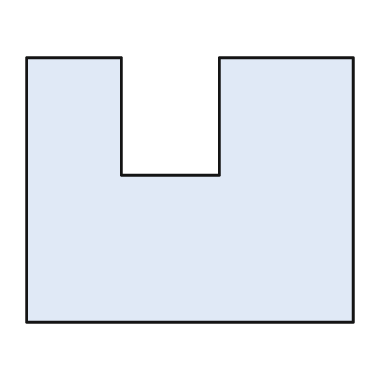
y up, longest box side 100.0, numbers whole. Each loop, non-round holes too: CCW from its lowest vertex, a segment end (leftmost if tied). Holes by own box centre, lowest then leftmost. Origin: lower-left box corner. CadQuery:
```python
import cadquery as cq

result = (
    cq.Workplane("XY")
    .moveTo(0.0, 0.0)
    .lineTo(100.0, 0.0)
    .lineTo(100.0, 81.0)
    .lineTo(59.0, 81.0)
    .lineTo(59.0, 45.0)
    .lineTo(29.0, 45.0)
    .lineTo(29.0, 81.0)
    .lineTo(0.0, 81.0)
    .close()
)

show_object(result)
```